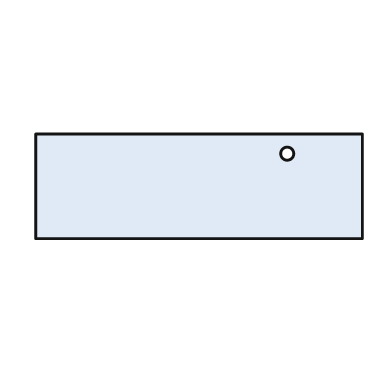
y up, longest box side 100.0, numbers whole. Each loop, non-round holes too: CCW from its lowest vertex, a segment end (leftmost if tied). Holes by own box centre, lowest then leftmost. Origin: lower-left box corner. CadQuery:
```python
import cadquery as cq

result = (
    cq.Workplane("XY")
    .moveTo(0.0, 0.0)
    .lineTo(100.0, 0.0)
    .lineTo(100.0, 32.0)
    .lineTo(0.0, 32.0)
    .close()
    .moveTo(77.0, 26.0)
    .circle(2.0)
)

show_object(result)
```